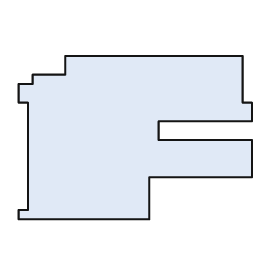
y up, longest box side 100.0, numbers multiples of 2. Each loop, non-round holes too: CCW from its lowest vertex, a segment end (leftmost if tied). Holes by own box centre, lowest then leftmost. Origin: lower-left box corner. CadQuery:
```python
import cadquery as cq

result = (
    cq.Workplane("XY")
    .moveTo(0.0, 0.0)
    .lineTo(56.0, 0.0)
    .lineTo(56.0, 18.0)
    .lineTo(100.0, 18.0)
    .lineTo(100.0, 34.0)
    .lineTo(60.0, 34.0)
    .lineTo(60.0, 42.0)
    .lineTo(100.0, 42.0)
    .lineTo(100.0, 50.0)
    .lineTo(96.0, 50.0)
    .lineTo(96.0, 70.0)
    .lineTo(20.0, 70.0)
    .lineTo(20.0, 62.0)
    .lineTo(6.0, 62.0)
    .lineTo(6.0, 58.0)
    .lineTo(0.0, 58.0)
    .lineTo(0.0, 50.0)
    .lineTo(4.0, 50.0)
    .lineTo(4.0, 4.0)
    .lineTo(0.0, 4.0)
    .close()
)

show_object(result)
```